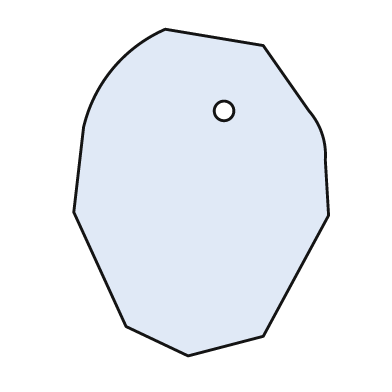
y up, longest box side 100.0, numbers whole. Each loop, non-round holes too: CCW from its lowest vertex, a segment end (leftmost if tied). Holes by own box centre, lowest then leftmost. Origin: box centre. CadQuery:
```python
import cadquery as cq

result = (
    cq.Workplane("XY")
    .moveTo(-4.0, -50.0)
    .lineTo(19.0, -44.0)
    .lineTo(39.0, -7.0)
    .lineTo(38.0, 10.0)
    .threePointArc((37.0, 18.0), (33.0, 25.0))
    .lineTo(19.0, 45.0)
    .lineTo(-11.0, 50.0)
    .threePointArc((-27.0, 38.0), (-36.0, 20.0))
    .lineTo(-39.0, -6.0)
    .lineTo(-23.0, -41.0)
    .close()
    .moveTo(7.0, 25.0)
    .circle(3.0)
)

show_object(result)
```